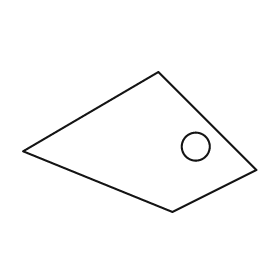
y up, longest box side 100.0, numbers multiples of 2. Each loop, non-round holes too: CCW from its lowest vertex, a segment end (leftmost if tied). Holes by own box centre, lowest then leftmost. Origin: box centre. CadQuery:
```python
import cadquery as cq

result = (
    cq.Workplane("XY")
    .moveTo(14.0, -30.0)
    .lineTo(50.0, -12.0)
    .lineTo(8.0, 30.0)
    .lineTo(-50.0, -4.0)
    .close()
    .moveTo(24.0, -2.0)
    .circle(6.0)
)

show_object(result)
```